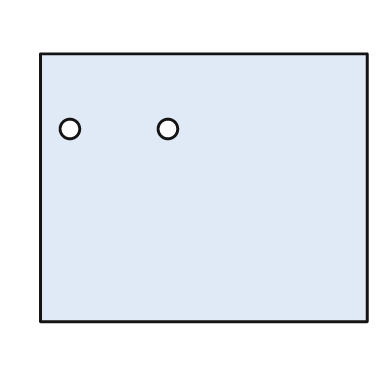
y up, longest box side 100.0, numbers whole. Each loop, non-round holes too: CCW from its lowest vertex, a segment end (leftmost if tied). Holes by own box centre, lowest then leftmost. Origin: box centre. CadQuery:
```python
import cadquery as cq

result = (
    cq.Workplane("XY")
    .moveTo(-50.0, -41.0)
    .lineTo(50.0, -41.0)
    .lineTo(50.0, 41.0)
    .lineTo(-50.0, 41.0)
    .close()
    .moveTo(-41.0, 18.0)
    .circle(3.0)
    .moveTo(-11.0, 18.0)
    .circle(3.0)
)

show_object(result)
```